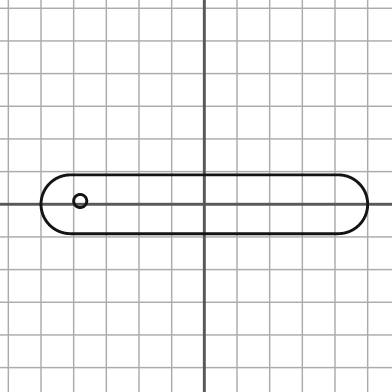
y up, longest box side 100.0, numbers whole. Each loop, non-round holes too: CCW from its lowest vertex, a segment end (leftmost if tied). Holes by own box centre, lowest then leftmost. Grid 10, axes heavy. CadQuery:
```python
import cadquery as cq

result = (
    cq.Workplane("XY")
    .moveTo(-41.0, -9.0)
    .lineTo(41.0, -9.0)
    .threePointArc((50.0, 0.0), (41.0, 9.0))
    .lineTo(-41.0, 9.0)
    .threePointArc((-50.0, 0.0), (-41.0, -9.0))
    .close()
    .moveTo(-38.0, 1.0)
    .circle(2.0)
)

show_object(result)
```